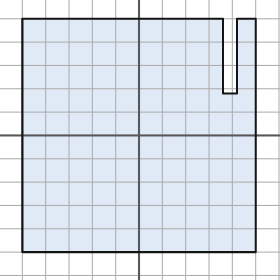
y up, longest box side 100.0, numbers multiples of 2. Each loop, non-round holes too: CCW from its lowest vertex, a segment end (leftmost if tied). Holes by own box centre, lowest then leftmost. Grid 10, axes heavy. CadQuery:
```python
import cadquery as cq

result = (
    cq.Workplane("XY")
    .moveTo(-50.0, -50.0)
    .lineTo(50.0, -50.0)
    .lineTo(50.0, 50.0)
    .lineTo(42.0, 50.0)
    .lineTo(42.0, 18.0)
    .lineTo(36.0, 18.0)
    .lineTo(36.0, 50.0)
    .lineTo(-50.0, 50.0)
    .close()
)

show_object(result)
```